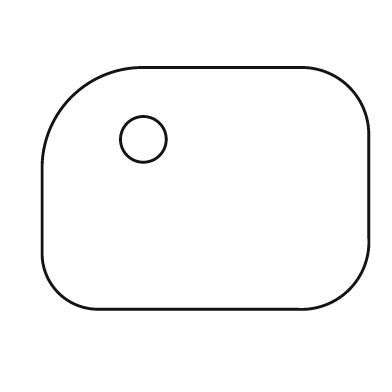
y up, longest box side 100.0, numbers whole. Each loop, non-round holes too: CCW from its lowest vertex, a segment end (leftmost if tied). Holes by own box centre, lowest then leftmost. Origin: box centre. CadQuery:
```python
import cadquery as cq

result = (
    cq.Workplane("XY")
    .moveTo(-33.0, -37.0)
    .lineTo(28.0, -37.0)
    .threePointArc((44.0, -31.0), (50.0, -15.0))
    .lineTo(50.0, 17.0)
    .threePointArc((44.0, 31.0), (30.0, 37.0))
    .lineTo(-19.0, 37.0)
    .threePointArc((-41.0, 28.0), (-50.0, 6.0))
    .lineTo(-50.0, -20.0)
    .threePointArc((-45.0, -32.0), (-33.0, -37.0))
    .close()
    .moveTo(-19.0, 15.0)
    .circle(7.0)
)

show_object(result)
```